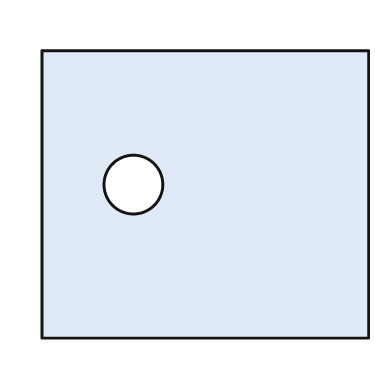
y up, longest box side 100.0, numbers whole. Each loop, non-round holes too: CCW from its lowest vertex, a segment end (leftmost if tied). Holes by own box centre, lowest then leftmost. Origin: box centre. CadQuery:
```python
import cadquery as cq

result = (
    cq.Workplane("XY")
    .moveTo(-50.0, -44.0)
    .lineTo(50.0, -44.0)
    .lineTo(50.0, 44.0)
    .lineTo(-50.0, 44.0)
    .close()
    .moveTo(-22.0, 3.0)
    .circle(9.0)
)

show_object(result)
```